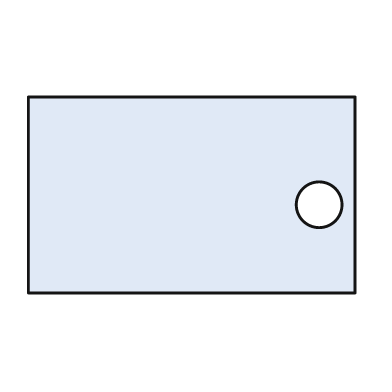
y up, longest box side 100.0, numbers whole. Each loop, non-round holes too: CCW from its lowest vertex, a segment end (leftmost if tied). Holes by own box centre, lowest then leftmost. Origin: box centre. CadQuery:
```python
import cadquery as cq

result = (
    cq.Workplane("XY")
    .moveTo(-50.0, -30.0)
    .lineTo(50.0, -30.0)
    .lineTo(50.0, 30.0)
    .lineTo(-50.0, 30.0)
    .close()
    .moveTo(39.0, -3.0)
    .circle(7.0)
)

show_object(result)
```